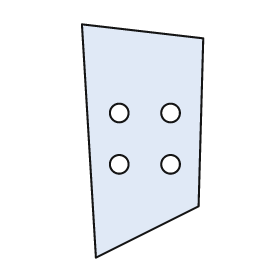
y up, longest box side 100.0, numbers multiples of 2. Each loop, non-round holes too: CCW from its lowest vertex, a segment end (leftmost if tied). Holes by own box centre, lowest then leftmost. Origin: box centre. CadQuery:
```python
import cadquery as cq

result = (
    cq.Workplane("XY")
    .moveTo(-20.0, -50.0)
    .lineTo(24.0, -28.0)
    .lineTo(26.0, 44.0)
    .lineTo(-26.0, 50.0)
    .close()
    .moveTo(-10.0, -10.0)
    .circle(4.0)
    .moveTo(12.0, -10.0)
    .circle(4.0)
    .moveTo(-10.0, 12.0)
    .circle(4.0)
    .moveTo(12.0, 12.0)
    .circle(4.0)
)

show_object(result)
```